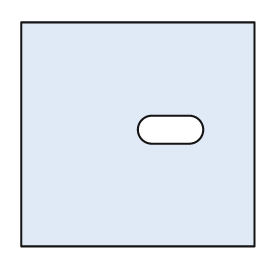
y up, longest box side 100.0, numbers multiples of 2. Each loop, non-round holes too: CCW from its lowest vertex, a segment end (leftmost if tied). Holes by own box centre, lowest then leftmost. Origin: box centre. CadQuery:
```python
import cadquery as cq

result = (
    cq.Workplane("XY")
    .moveTo(-50.0, -48.0)
    .lineTo(50.0, -48.0)
    .lineTo(50.0, 48.0)
    .lineTo(-50.0, 48.0)
    .close()
    .moveTo(6.0, -4.0)
    .lineTo(22.0, -4.0)
    .threePointArc((28.0, 2.0), (22.0, 8.0))
    .lineTo(6.0, 8.0)
    .threePointArc((0.0, 2.0), (6.0, -4.0))
    .close()
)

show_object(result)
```